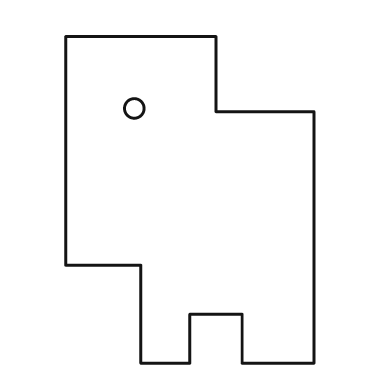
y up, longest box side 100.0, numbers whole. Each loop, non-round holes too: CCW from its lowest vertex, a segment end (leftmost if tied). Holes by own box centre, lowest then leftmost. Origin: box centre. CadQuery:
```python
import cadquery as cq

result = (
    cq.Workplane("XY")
    .moveTo(-15.0, -50.0)
    .lineTo(0.0, -50.0)
    .lineTo(0.0, -35.0)
    .lineTo(16.0, -35.0)
    .lineTo(16.0, -50.0)
    .lineTo(38.0, -50.0)
    .lineTo(38.0, 27.0)
    .lineTo(8.0, 27.0)
    .lineTo(8.0, 50.0)
    .lineTo(-38.0, 50.0)
    .lineTo(-38.0, -20.0)
    .lineTo(-15.0, -20.0)
    .close()
    .moveTo(-17.0, 28.0)
    .circle(3.0)
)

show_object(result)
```